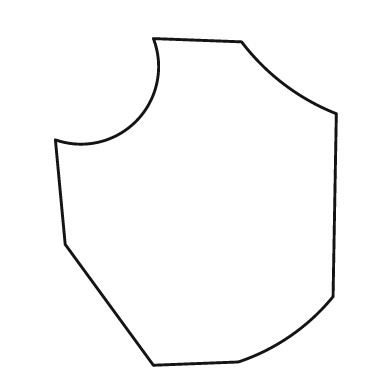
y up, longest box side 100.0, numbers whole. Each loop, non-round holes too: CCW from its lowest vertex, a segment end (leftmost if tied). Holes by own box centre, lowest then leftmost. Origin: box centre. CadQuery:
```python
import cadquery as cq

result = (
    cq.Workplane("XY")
    .moveTo(-13.0, -50.0)
    .lineTo(13.0, -49.0)
    .threePointArc((29.0, -41.0), (42.0, -29.0))
    .lineTo(43.0, 27.0)
    .threePointArc((27.0, 36.0), (14.0, 49.0))
    .lineTo(-13.0, 50.0)
    .threePointArc((-18.0, 25.0), (-43.0, 19.0))
    .lineTo(-40.0, -13.0)
    .close()
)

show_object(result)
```